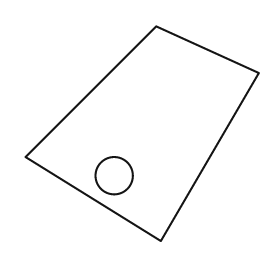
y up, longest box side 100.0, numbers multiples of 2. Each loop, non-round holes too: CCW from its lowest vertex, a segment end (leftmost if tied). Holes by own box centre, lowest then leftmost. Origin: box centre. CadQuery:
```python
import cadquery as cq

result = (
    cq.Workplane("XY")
    .moveTo(8.0, -46.0)
    .lineTo(50.0, 26.0)
    .lineTo(6.0, 46.0)
    .lineTo(-50.0, -10.0)
    .close()
    .moveTo(-12.0, -18.0)
    .circle(8.0)
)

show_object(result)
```